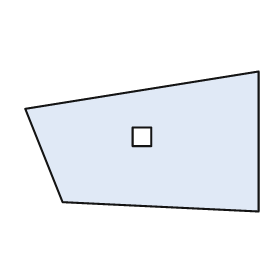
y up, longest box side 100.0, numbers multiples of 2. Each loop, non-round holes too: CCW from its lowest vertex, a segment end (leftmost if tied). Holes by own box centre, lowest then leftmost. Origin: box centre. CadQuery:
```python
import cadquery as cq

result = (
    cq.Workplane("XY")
    .moveTo(50.0, -30.0)
    .lineTo(50.0, 30.0)
    .lineTo(-50.0, 14.0)
    .lineTo(-34.0, -26.0)
    .close()
    .moveTo(-4.0, -2.0)
    .lineTo(4.0, -2.0)
    .lineTo(4.0, 6.0)
    .lineTo(-4.0, 6.0)
    .close()
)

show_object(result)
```